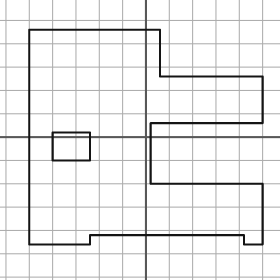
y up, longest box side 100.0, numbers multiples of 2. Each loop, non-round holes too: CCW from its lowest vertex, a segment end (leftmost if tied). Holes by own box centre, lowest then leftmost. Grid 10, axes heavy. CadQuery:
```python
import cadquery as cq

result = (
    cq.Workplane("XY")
    .moveTo(-50.0, -46.0)
    .lineTo(-24.0, -46.0)
    .lineTo(-24.0, -42.0)
    .lineTo(42.0, -42.0)
    .lineTo(42.0, -46.0)
    .lineTo(50.0, -46.0)
    .lineTo(50.0, -20.0)
    .lineTo(2.0, -20.0)
    .lineTo(2.0, 6.0)
    .lineTo(50.0, 6.0)
    .lineTo(50.0, 26.0)
    .lineTo(6.0, 26.0)
    .lineTo(6.0, 46.0)
    .lineTo(-50.0, 46.0)
    .close()
    .moveTo(-40.0, -10.0)
    .lineTo(-24.0, -10.0)
    .lineTo(-24.0, 2.0)
    .lineTo(-40.0, 2.0)
    .close()
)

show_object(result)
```